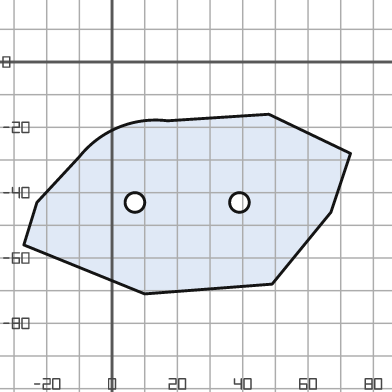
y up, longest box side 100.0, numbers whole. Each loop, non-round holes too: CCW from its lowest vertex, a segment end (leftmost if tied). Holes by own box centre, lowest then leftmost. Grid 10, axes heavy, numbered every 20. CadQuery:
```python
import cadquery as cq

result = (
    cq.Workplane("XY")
    .moveTo(10.0, -71.0)
    .lineTo(49.0, -68.0)
    .lineTo(67.0, -46.0)
    .lineTo(73.0, -28.0)
    .lineTo(48.0, -16.0)
    .lineTo(17.0, -18.0)
    .threePointArc((2.0, -20.0), (-10.0, -29.0))
    .lineTo(-23.0, -43.0)
    .lineTo(-27.0, -56.0)
    .close()
    .moveTo(7.0, -43.0)
    .circle(3.0)
    .moveTo(39.0, -43.0)
    .circle(3.0)
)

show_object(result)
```